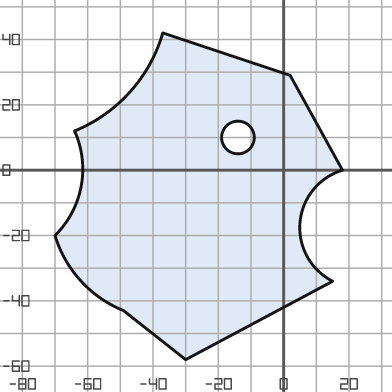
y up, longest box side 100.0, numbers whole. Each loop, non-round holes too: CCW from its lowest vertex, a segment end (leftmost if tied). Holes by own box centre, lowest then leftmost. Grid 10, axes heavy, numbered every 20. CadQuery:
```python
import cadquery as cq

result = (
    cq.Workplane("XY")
    .moveTo(-30.0, -58.0)
    .lineTo(15.0, -34.0)
    .threePointArc((5.0, -16.0), (18.0, 0.0))
    .lineTo(2.0, 29.0)
    .lineTo(-37.0, 42.0)
    .threePointArc((-47.0, 24.0), (-64.0, 12.0))
    .threePointArc((-62.0, -5.0), (-70.0, -20.0))
    .threePointArc((-62.0, -34.0), (-49.0, -43.0))
    .close()
    .moveTo(-14.0, 10.0)
    .circle(5.0)
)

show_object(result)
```